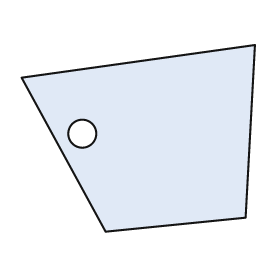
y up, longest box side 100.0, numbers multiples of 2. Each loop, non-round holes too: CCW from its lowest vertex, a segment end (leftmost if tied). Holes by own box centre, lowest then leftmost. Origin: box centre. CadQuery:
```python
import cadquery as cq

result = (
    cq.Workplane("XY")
    .moveTo(-14.0, -40.0)
    .lineTo(46.0, -34.0)
    .lineTo(50.0, 40.0)
    .lineTo(-50.0, 26.0)
    .close()
    .moveTo(-24.0, 2.0)
    .circle(6.0)
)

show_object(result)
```